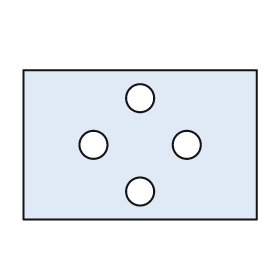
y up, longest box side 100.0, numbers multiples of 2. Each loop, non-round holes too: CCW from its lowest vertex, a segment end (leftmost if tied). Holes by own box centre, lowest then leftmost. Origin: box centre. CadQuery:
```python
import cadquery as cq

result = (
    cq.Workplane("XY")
    .moveTo(-50.0, -32.0)
    .lineTo(50.0, -32.0)
    .lineTo(50.0, 32.0)
    .lineTo(-50.0, 32.0)
    .close()
    .moveTo(0.0, -20.0)
    .circle(6.0)
    .moveTo(-20.0, 0.0)
    .circle(6.0)
    .moveTo(20.0, 0.0)
    .circle(6.0)
    .moveTo(0.0, 20.0)
    .circle(6.0)
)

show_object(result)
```